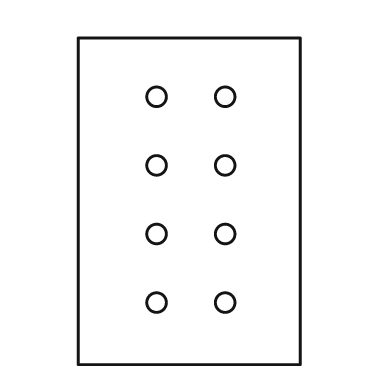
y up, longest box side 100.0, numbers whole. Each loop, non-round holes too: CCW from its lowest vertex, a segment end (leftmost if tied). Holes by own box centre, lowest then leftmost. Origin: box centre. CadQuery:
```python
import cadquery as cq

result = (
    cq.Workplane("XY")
    .moveTo(-34.0, -50.0)
    .lineTo(34.0, -50.0)
    .lineTo(34.0, 50.0)
    .lineTo(-34.0, 50.0)
    .close()
    .moveTo(-10.0, -31.0)
    .circle(3.0)
    .moveTo(11.0, -31.0)
    .circle(3.0)
    .moveTo(-10.0, -10.0)
    .circle(3.0)
    .moveTo(11.0, -10.0)
    .circle(3.0)
    .moveTo(-10.0, 11.0)
    .circle(3.0)
    .moveTo(11.0, 11.0)
    .circle(3.0)
    .moveTo(-10.0, 32.0)
    .circle(3.0)
    .moveTo(11.0, 32.0)
    .circle(3.0)
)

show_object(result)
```